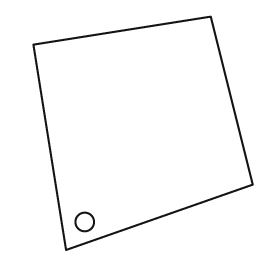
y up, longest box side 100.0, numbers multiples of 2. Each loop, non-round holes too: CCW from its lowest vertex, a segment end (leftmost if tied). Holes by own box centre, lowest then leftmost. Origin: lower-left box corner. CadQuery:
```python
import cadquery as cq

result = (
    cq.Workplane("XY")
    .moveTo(14.0, 0.0)
    .lineTo(94.0, 28.0)
    .lineTo(76.0, 100.0)
    .lineTo(0.0, 88.0)
    .close()
    .moveTo(22.0, 12.0)
    .circle(4.0)
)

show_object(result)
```